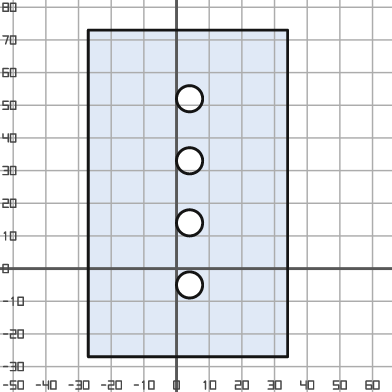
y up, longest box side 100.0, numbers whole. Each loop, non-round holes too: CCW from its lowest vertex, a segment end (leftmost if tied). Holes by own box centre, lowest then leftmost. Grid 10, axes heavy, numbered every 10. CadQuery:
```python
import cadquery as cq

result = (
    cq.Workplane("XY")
    .moveTo(-27.0, -27.0)
    .lineTo(34.0, -27.0)
    .lineTo(34.0, 73.0)
    .lineTo(-27.0, 73.0)
    .close()
    .moveTo(4.0, -5.0)
    .circle(4.0)
    .moveTo(4.0, 14.0)
    .circle(4.0)
    .moveTo(4.0, 33.0)
    .circle(4.0)
    .moveTo(4.0, 52.0)
    .circle(4.0)
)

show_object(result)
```